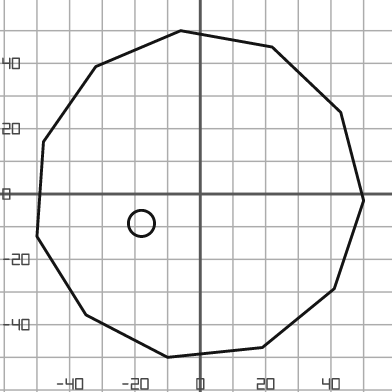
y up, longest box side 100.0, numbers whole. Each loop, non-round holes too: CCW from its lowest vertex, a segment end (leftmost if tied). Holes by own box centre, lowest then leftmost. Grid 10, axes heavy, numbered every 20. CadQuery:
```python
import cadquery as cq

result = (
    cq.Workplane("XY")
    .moveTo(-10.0, -50.0)
    .lineTo(19.0, -47.0)
    .lineTo(41.0, -29.0)
    .lineTo(50.0, -2.0)
    .lineTo(43.0, 25.0)
    .lineTo(22.0, 45.0)
    .lineTo(-6.0, 50.0)
    .lineTo(-32.0, 39.0)
    .lineTo(-48.0, 16.0)
    .lineTo(-50.0, -13.0)
    .lineTo(-35.0, -37.0)
    .close()
    .moveTo(-18.0, -9.0)
    .circle(4.0)
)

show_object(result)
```